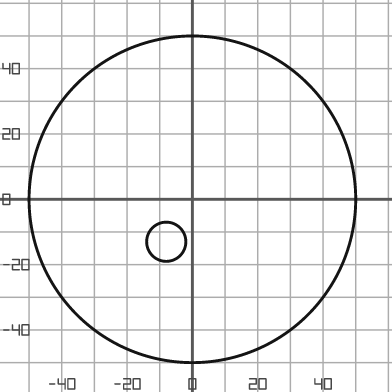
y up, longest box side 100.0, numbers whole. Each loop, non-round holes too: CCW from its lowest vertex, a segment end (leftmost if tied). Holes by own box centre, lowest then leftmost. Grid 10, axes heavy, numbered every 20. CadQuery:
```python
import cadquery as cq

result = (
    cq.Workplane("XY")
    .moveTo(0.0, 0.0)
    .circle(50.0)
    .moveTo(-8.0, -13.0)
    .circle(6.0)
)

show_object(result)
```